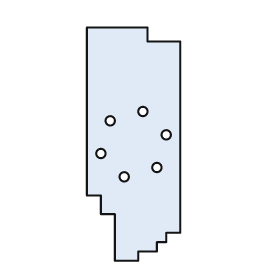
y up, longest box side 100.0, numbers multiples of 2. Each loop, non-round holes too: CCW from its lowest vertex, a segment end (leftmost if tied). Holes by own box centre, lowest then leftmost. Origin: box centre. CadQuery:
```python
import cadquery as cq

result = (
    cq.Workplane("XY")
    .moveTo(-8.0, -50.0)
    .lineTo(2.0, -50.0)
    .lineTo(2.0, -46.0)
    .lineTo(10.0, -46.0)
    .lineTo(10.0, -42.0)
    .lineTo(14.0, -42.0)
    .lineTo(14.0, -38.0)
    .lineTo(20.0, -38.0)
    .lineTo(20.0, 44.0)
    .lineTo(6.0, 44.0)
    .lineTo(6.0, 50.0)
    .lineTo(-20.0, 50.0)
    .lineTo(-20.0, -22.0)
    .lineTo(-14.0, -22.0)
    .lineTo(-14.0, -30.0)
    .lineTo(-8.0, -30.0)
    .close()
    .moveTo(-4.0, -14.0)
    .circle(2.0)
    .moveTo(10.0, -10.0)
    .circle(2.0)
    .moveTo(-14.0, -4.0)
    .circle(2.0)
    .moveTo(14.0, 4.0)
    .circle(2.0)
    .moveTo(-10.0, 10.0)
    .circle(2.0)
    .moveTo(4.0, 14.0)
    .circle(2.0)
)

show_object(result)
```